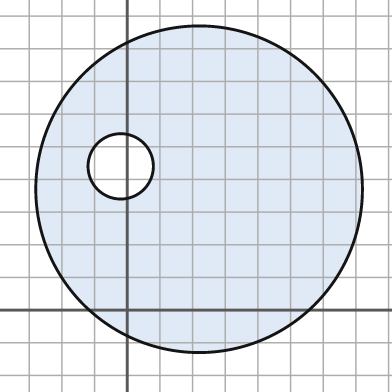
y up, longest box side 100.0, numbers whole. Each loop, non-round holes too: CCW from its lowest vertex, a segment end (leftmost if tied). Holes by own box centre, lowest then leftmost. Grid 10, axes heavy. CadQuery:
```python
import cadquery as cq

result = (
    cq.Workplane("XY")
    .moveTo(22.0, 37.0)
    .circle(50.0)
    .moveTo(-2.0, 44.0)
    .circle(10.0)
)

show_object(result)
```